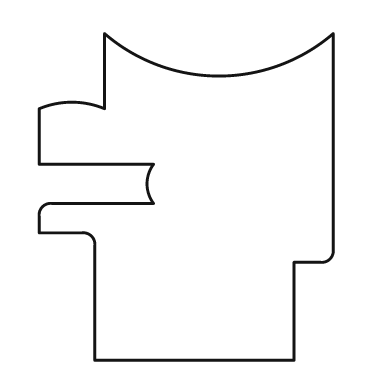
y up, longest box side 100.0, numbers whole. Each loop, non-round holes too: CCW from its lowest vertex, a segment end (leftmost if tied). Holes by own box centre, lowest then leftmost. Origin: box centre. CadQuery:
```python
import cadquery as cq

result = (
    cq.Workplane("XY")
    .moveTo(-28.0, -50.0)
    .lineTo(33.0, -50.0)
    .lineTo(33.0, -20.0)
    .lineTo(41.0, -20.0)
    .threePointArc((44.0, -19.0), (45.0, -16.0))
    .lineTo(45.0, 50.0)
    .threePointArc((10.0, 37.0), (-25.0, 50.0))
    .lineTo(-25.0, 27.0)
    .threePointArc((-35.0, 29.0), (-45.0, 27.0))
    .lineTo(-45.0, 10.0)
    .lineTo(-10.0, 10.0)
    .threePointArc((-12.0, 4.0), (-10.0, -2.0))
    .lineTo(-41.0, -2.0)
    .threePointArc((-44.0, -3.0), (-45.0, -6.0))
    .lineTo(-45.0, -11.0)
    .lineTo(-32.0, -11.0)
    .threePointArc((-29.0, -12.0), (-28.0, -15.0))
    .close()
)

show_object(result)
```